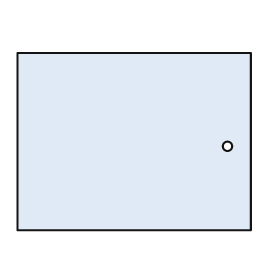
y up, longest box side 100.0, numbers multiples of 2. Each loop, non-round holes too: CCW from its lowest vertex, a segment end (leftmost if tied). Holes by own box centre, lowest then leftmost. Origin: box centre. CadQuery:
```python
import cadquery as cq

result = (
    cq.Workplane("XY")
    .moveTo(-50.0, -38.0)
    .lineTo(50.0, -38.0)
    .lineTo(50.0, 38.0)
    .lineTo(-50.0, 38.0)
    .close()
    .moveTo(40.0, -2.0)
    .circle(2.0)
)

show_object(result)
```